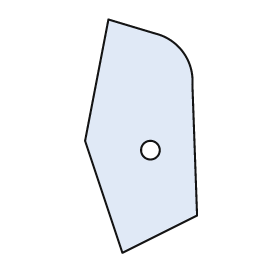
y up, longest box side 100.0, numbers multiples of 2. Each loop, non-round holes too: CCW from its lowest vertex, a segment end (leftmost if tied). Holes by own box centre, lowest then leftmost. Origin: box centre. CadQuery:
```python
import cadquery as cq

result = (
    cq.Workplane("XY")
    .moveTo(-8.0, -50.0)
    .lineTo(24.0, -34.0)
    .lineTo(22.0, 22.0)
    .threePointArc((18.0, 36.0), (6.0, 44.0))
    .lineTo(-14.0, 50.0)
    .lineTo(-24.0, -2.0)
    .close()
    .moveTo(4.0, -6.0)
    .circle(4.0)
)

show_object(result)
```